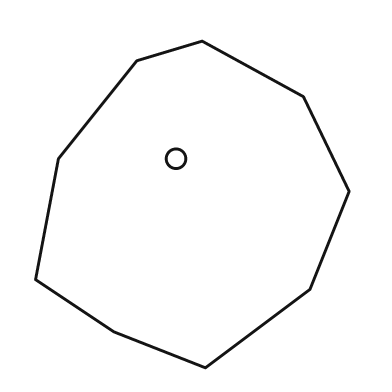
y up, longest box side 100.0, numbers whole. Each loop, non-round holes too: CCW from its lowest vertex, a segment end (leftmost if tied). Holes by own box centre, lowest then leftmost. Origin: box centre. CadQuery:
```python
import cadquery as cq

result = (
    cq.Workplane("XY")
    .moveTo(4.0, -50.0)
    .lineTo(36.0, -26.0)
    .lineTo(48.0, 4.0)
    .lineTo(34.0, 33.0)
    .lineTo(3.0, 50.0)
    .lineTo(-17.0, 44.0)
    .lineTo(-41.0, 14.0)
    .lineTo(-48.0, -23.0)
    .lineTo(-24.0, -39.0)
    .close()
    .moveTo(-5.0, 14.0)
    .circle(3.0)
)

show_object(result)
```